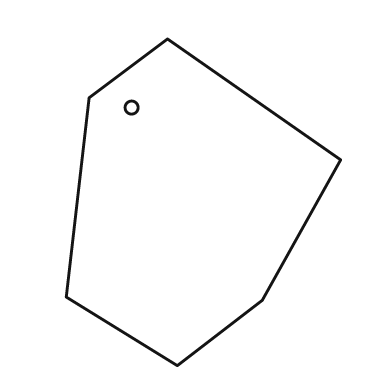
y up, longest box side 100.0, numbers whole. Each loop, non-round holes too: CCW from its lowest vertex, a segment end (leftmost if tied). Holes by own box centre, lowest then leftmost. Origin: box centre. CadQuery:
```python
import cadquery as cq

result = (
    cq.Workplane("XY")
    .moveTo(-8.0, -50.0)
    .lineTo(18.0, -30.0)
    .lineTo(42.0, 13.0)
    .lineTo(-11.0, 50.0)
    .lineTo(-35.0, 32.0)
    .lineTo(-42.0, -29.0)
    .close()
    .moveTo(-22.0, 29.0)
    .circle(2.0)
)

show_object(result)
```